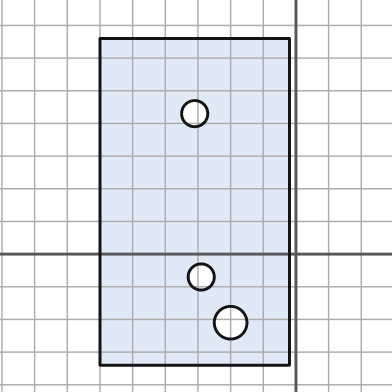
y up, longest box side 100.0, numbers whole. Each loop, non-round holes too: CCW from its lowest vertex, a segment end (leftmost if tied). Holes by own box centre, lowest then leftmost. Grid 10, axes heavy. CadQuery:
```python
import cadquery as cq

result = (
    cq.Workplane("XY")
    .moveTo(-60.0, -34.0)
    .lineTo(-2.0, -34.0)
    .lineTo(-2.0, 66.0)
    .lineTo(-60.0, 66.0)
    .close()
    .moveTo(-20.0, -21.0)
    .circle(5.0)
    .moveTo(-29.0, -7.0)
    .circle(4.0)
    .moveTo(-31.0, 43.0)
    .circle(4.0)
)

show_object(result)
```